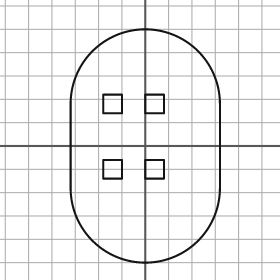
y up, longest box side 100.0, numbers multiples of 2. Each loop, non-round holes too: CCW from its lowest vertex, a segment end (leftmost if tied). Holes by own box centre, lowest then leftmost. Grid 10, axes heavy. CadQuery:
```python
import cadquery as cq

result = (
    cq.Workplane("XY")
    .moveTo(-32.0, -18.0)
    .threePointArc((0.0, -50.0), (32.0, -18.0))
    .lineTo(32.0, 18.0)
    .threePointArc((0.0, 50.0), (-32.0, 18.0))
    .close()
    .moveTo(-18.0, -14.0)
    .lineTo(-10.0, -14.0)
    .lineTo(-10.0, -6.0)
    .lineTo(-18.0, -6.0)
    .close()
    .moveTo(0.0, -14.0)
    .lineTo(8.0, -14.0)
    .lineTo(8.0, -6.0)
    .lineTo(0.0, -6.0)
    .close()
    .moveTo(-18.0, 14.0)
    .lineTo(-10.0, 14.0)
    .lineTo(-10.0, 22.0)
    .lineTo(-18.0, 22.0)
    .close()
    .moveTo(0.0, 14.0)
    .lineTo(8.0, 14.0)
    .lineTo(8.0, 22.0)
    .lineTo(0.0, 22.0)
    .close()
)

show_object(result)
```